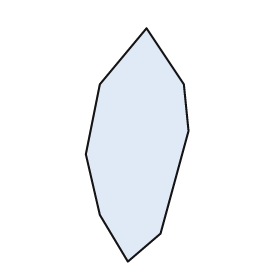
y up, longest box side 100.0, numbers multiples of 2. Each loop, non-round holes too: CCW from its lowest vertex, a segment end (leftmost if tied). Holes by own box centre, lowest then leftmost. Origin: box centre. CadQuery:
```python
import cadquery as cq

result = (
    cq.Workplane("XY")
    .moveTo(-4.0, -50.0)
    .lineTo(10.0, -38.0)
    .lineTo(22.0, 6.0)
    .lineTo(20.0, 26.0)
    .lineTo(4.0, 50.0)
    .lineTo(-16.0, 26.0)
    .lineTo(-22.0, -4.0)
    .lineTo(-16.0, -30.0)
    .close()
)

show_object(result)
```